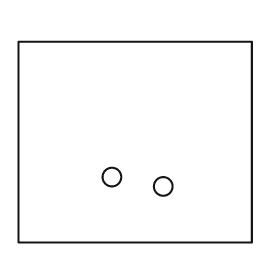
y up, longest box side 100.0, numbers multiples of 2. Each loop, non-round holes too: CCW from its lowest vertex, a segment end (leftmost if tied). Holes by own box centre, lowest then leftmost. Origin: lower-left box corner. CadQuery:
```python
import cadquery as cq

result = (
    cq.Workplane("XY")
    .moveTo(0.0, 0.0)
    .lineTo(100.0, 0.0)
    .lineTo(100.0, 86.0)
    .lineTo(0.0, 86.0)
    .close()
    .moveTo(62.0, 24.0)
    .circle(4.0)
    .moveTo(40.0, 28.0)
    .circle(4.0)
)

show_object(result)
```